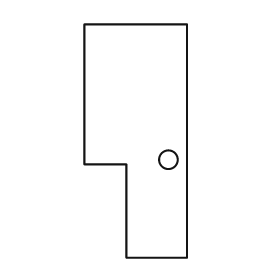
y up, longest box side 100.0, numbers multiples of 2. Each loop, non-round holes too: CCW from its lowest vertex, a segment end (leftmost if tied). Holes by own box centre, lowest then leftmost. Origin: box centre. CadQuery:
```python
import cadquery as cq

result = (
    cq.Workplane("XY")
    .moveTo(-4.0, -50.0)
    .lineTo(22.0, -50.0)
    .lineTo(22.0, 50.0)
    .lineTo(-22.0, 50.0)
    .lineTo(-22.0, -10.0)
    .lineTo(-4.0, -10.0)
    .close()
    .moveTo(14.0, -8.0)
    .circle(4.0)
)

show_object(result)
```